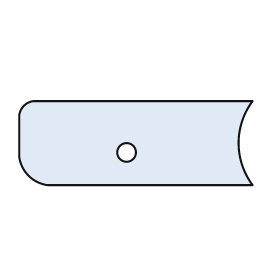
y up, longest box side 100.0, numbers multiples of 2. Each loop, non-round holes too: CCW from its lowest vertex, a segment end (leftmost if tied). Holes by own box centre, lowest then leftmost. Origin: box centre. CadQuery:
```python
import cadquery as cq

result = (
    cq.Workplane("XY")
    .moveTo(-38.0, -18.0)
    .lineTo(50.0, -18.0)
    .threePointArc((44.0, 0.0), (50.0, 18.0))
    .lineTo(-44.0, 18.0)
    .threePointArc((-48.0, 16.0), (-50.0, 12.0))
    .lineTo(-50.0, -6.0)
    .threePointArc((-46.0, -14.0), (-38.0, -18.0))
    .close()
    .moveTo(-4.0, -4.0)
    .circle(4.0)
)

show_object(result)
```